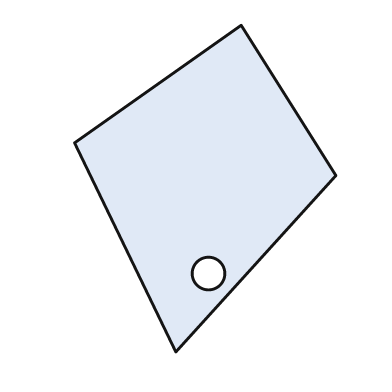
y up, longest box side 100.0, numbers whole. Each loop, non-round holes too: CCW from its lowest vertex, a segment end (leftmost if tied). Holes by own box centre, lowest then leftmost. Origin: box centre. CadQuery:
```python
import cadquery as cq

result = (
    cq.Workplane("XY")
    .moveTo(-9.0, -50.0)
    .lineTo(40.0, 4.0)
    .lineTo(11.0, 50.0)
    .lineTo(-40.0, 14.0)
    .close()
    .moveTo(1.0, -26.0)
    .circle(5.0)
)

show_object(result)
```